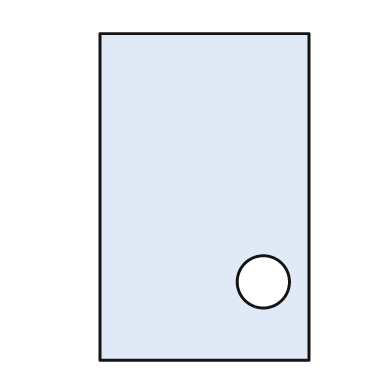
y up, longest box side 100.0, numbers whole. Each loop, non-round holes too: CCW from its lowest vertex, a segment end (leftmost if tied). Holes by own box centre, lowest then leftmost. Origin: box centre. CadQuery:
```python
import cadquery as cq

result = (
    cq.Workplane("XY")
    .moveTo(-32.0, -50.0)
    .lineTo(32.0, -50.0)
    .lineTo(32.0, 50.0)
    .lineTo(-32.0, 50.0)
    .close()
    .moveTo(18.0, -26.0)
    .circle(8.0)
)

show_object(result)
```